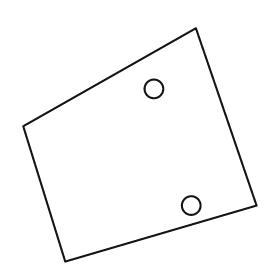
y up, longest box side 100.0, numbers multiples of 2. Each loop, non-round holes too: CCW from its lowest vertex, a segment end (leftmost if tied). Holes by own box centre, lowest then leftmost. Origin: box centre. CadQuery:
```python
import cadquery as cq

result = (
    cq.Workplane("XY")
    .moveTo(-32.0, -50.0)
    .lineTo(50.0, -26.0)
    .lineTo(24.0, 50.0)
    .lineTo(-50.0, 8.0)
    .close()
    .moveTo(22.0, -26.0)
    .circle(4.0)
    .moveTo(6.0, 24.0)
    .circle(4.0)
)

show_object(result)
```